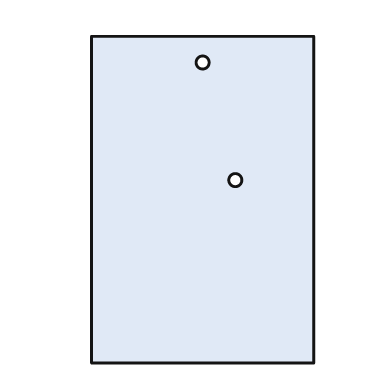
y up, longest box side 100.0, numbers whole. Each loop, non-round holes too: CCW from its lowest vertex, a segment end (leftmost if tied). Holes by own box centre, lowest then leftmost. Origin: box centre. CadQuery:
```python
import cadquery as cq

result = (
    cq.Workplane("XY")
    .moveTo(-34.0, -50.0)
    .lineTo(34.0, -50.0)
    .lineTo(34.0, 50.0)
    .lineTo(-34.0, 50.0)
    .close()
    .moveTo(10.0, 6.0)
    .circle(2.0)
    .moveTo(0.0, 42.0)
    .circle(2.0)
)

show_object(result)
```